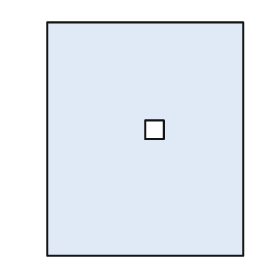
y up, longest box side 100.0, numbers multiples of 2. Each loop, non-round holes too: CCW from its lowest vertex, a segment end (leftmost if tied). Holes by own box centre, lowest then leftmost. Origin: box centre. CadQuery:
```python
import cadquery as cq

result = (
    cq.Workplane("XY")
    .moveTo(-42.0, -50.0)
    .lineTo(42.0, -50.0)
    .lineTo(42.0, 50.0)
    .lineTo(-42.0, 50.0)
    .close()
    .moveTo(0.0, 0.0)
    .lineTo(8.0, 0.0)
    .lineTo(8.0, 8.0)
    .lineTo(0.0, 8.0)
    .close()
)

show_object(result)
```